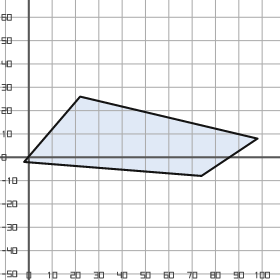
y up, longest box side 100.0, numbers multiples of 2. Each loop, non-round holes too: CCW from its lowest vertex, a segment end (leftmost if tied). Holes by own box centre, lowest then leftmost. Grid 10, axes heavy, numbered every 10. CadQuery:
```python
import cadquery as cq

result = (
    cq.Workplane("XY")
    .moveTo(74.0, -8.0)
    .lineTo(98.0, 8.0)
    .lineTo(22.0, 26.0)
    .lineTo(-2.0, -2.0)
    .close()
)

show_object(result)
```